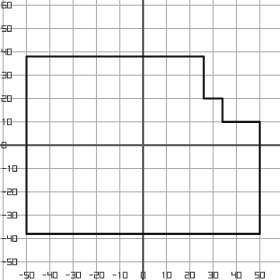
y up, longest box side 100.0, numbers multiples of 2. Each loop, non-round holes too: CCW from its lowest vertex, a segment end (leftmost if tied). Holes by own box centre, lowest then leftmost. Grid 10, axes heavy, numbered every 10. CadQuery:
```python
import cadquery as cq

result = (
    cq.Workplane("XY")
    .moveTo(-50.0, -38.0)
    .lineTo(50.0, -38.0)
    .lineTo(50.0, 10.0)
    .lineTo(34.0, 10.0)
    .lineTo(34.0, 20.0)
    .lineTo(26.0, 20.0)
    .lineTo(26.0, 38.0)
    .lineTo(-50.0, 38.0)
    .close()
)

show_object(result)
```